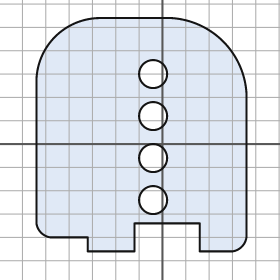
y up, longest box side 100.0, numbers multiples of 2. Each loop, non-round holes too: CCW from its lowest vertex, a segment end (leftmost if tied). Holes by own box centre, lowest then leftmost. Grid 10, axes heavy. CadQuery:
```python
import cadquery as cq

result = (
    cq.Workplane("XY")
    .moveTo(-32.0, -46.0)
    .lineTo(-12.0, -46.0)
    .lineTo(-12.0, -34.0)
    .lineTo(16.0, -34.0)
    .lineTo(16.0, -46.0)
    .lineTo(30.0, -46.0)
    .threePointArc((34.0, -44.0), (36.0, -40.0))
    .lineTo(36.0, 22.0)
    .threePointArc((26.0, 44.0), (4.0, 54.0))
    .lineTo(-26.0, 54.0)
    .threePointArc((-46.0, 46.0), (-54.0, 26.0))
    .lineTo(-54.0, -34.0)
    .threePointArc((-52.0, -38.0), (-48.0, -40.0))
    .lineTo(-32.0, -40.0)
    .close()
    .moveTo(-4.0, -24.0)
    .circle(6.0)
    .moveTo(-4.0, -6.0)
    .circle(6.0)
    .moveTo(-4.0, 12.0)
    .circle(6.0)
    .moveTo(-4.0, 30.0)
    .circle(6.0)
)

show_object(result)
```